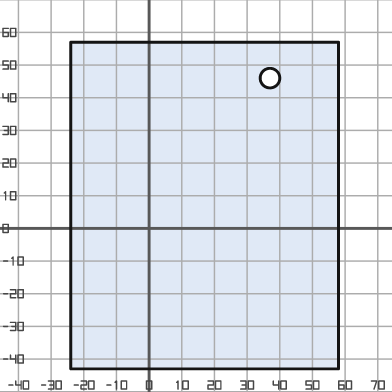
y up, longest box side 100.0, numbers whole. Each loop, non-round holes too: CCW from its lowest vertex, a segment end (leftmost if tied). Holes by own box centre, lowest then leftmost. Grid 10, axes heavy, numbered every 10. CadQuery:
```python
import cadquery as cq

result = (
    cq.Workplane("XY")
    .moveTo(-24.0, -43.0)
    .lineTo(58.0, -43.0)
    .lineTo(58.0, 57.0)
    .lineTo(-24.0, 57.0)
    .close()
    .moveTo(37.0, 46.0)
    .circle(3.0)
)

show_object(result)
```